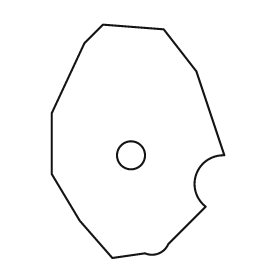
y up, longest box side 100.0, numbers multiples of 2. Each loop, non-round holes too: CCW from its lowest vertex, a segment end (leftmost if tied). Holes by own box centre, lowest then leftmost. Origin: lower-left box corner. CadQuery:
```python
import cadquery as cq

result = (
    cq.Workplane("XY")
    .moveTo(26.0, 0.0)
    .lineTo(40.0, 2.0)
    .threePointArc((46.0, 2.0), (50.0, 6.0))
    .lineTo(66.0, 22.0)
    .threePointArc((62.0, 36.0), (74.0, 44.0))
    .lineTo(62.0, 80.0)
    .lineTo(48.0, 98.0)
    .lineTo(22.0, 100.0)
    .lineTo(14.0, 92.0)
    .lineTo(0.0, 62.0)
    .lineTo(0.0, 36.0)
    .lineTo(12.0, 16.0)
    .close()
    .moveTo(34.0, 44.0)
    .circle(6.0)
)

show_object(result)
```